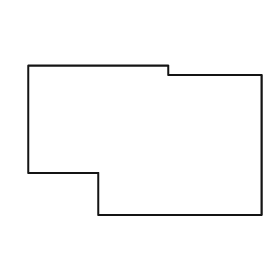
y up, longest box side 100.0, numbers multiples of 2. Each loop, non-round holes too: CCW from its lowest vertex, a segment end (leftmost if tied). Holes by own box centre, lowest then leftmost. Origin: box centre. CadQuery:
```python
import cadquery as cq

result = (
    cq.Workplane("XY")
    .moveTo(-20.0, -32.0)
    .lineTo(50.0, -32.0)
    .lineTo(50.0, 28.0)
    .lineTo(10.0, 28.0)
    .lineTo(10.0, 32.0)
    .lineTo(-50.0, 32.0)
    .lineTo(-50.0, -14.0)
    .lineTo(-20.0, -14.0)
    .close()
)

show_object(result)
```